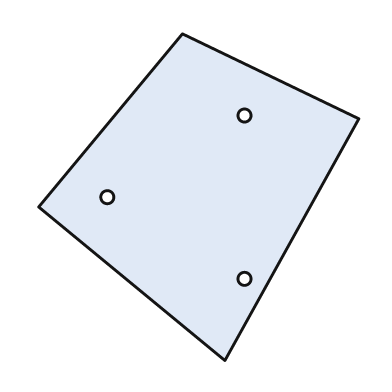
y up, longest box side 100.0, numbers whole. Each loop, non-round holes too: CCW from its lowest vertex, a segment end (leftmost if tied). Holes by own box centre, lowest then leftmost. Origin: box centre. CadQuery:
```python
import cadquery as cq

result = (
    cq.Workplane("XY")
    .moveTo(8.0, -50.0)
    .lineTo(49.0, 24.0)
    .lineTo(-5.0, 50.0)
    .lineTo(-49.0, -3.0)
    .close()
    .moveTo(14.0, -25.0)
    .circle(2.0)
    .moveTo(-28.0, 0.0)
    .circle(2.0)
    .moveTo(14.0, 25.0)
    .circle(2.0)
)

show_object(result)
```